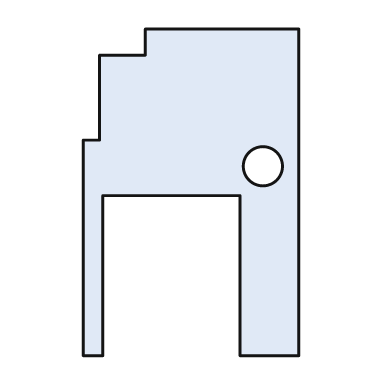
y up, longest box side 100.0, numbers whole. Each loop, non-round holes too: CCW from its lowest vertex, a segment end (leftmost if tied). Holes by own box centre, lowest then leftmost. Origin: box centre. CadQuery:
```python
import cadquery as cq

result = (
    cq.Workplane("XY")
    .moveTo(-33.0, -50.0)
    .lineTo(-27.0, -50.0)
    .lineTo(-27.0, -1.0)
    .lineTo(15.0, -1.0)
    .lineTo(15.0, -50.0)
    .lineTo(33.0, -50.0)
    .lineTo(33.0, 50.0)
    .lineTo(-14.0, 50.0)
    .lineTo(-14.0, 42.0)
    .lineTo(-28.0, 42.0)
    .lineTo(-28.0, 16.0)
    .lineTo(-33.0, 16.0)
    .close()
    .moveTo(22.0, 8.0)
    .circle(6.0)
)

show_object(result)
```